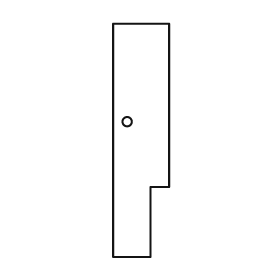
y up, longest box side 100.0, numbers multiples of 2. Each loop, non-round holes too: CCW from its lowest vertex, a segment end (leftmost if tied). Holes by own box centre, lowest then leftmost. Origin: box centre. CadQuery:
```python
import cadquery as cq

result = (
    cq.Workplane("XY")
    .moveTo(-12.0, -50.0)
    .lineTo(4.0, -50.0)
    .lineTo(4.0, -20.0)
    .lineTo(12.0, -20.0)
    .lineTo(12.0, 50.0)
    .lineTo(-12.0, 50.0)
    .close()
    .moveTo(-6.0, 8.0)
    .circle(2.0)
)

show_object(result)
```